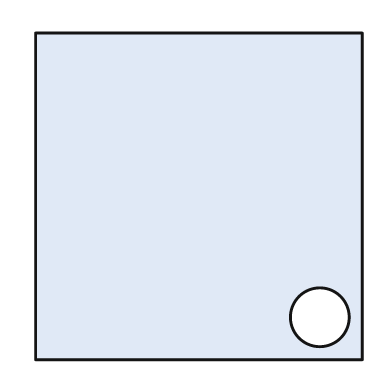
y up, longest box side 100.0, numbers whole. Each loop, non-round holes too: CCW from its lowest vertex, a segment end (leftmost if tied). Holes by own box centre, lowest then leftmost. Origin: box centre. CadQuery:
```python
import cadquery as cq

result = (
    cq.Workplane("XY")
    .moveTo(-50.0, -50.0)
    .lineTo(50.0, -50.0)
    .lineTo(50.0, 50.0)
    .lineTo(-50.0, 50.0)
    .close()
    .moveTo(37.0, -37.0)
    .circle(9.0)
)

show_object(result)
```